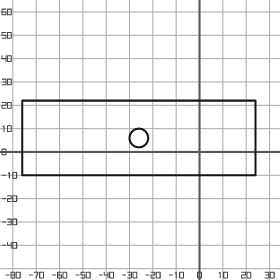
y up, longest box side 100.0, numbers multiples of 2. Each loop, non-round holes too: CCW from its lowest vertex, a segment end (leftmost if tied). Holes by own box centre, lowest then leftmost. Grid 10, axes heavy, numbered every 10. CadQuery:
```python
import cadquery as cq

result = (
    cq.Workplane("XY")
    .moveTo(-76.0, -10.0)
    .lineTo(24.0, -10.0)
    .lineTo(24.0, 22.0)
    .lineTo(-76.0, 22.0)
    .close()
    .moveTo(-26.0, 6.0)
    .circle(4.0)
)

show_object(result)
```